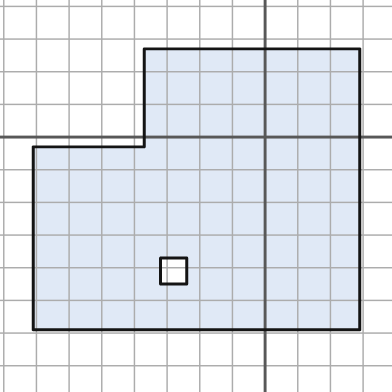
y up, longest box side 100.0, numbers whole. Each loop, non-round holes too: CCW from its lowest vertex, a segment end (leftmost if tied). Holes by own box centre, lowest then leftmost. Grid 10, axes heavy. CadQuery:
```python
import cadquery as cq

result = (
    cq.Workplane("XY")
    .moveTo(-71.0, -59.0)
    .lineTo(29.0, -59.0)
    .lineTo(29.0, 27.0)
    .lineTo(-37.0, 27.0)
    .lineTo(-37.0, -3.0)
    .lineTo(-71.0, -3.0)
    .close()
    .moveTo(-32.0, -45.0)
    .lineTo(-24.0, -45.0)
    .lineTo(-24.0, -37.0)
    .lineTo(-32.0, -37.0)
    .close()
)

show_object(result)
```